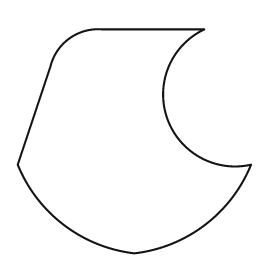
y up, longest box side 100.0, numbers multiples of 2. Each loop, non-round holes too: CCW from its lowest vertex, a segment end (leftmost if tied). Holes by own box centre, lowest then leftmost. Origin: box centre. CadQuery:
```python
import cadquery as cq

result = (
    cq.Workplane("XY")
    .moveTo(0.0, -48.0)
    .threePointArc((30.0, -36.0), (50.0, -10.0))
    .threePointArc((14.0, 10.0), (30.0, 48.0))
    .lineTo(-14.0, 48.0)
    .threePointArc((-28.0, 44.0), (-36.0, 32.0))
    .lineTo(-50.0, -10.0)
    .threePointArc((-30.0, -36.0), (0.0, -48.0))
    .close()
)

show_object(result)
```